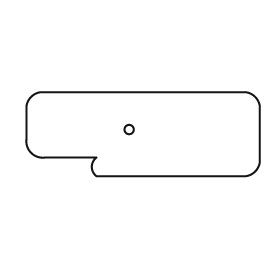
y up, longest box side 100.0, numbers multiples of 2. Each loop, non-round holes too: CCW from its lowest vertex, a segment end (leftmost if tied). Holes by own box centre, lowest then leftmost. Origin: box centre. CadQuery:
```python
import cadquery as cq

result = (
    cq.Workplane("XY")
    .moveTo(-20.0, -18.0)
    .lineTo(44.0, -18.0)
    .threePointArc((48.0, -16.0), (50.0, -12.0))
    .lineTo(50.0, 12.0)
    .threePointArc((48.0, 16.0), (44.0, 18.0))
    .lineTo(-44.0, 18.0)
    .threePointArc((-48.0, 16.0), (-50.0, 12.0))
    .lineTo(-50.0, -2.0)
    .threePointArc((-48.0, -8.0), (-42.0, -10.0))
    .lineTo(-20.0, -10.0)
    .threePointArc((-22.0, -14.0), (-20.0, -18.0))
    .close()
    .moveTo(-6.0, 2.0)
    .circle(2.0)
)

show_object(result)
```